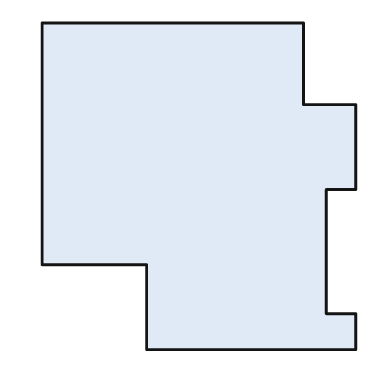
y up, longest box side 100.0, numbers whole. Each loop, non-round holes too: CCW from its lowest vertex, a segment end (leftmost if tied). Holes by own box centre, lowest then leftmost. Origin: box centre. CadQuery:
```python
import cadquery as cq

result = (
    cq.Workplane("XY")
    .moveTo(-16.0, -50.0)
    .lineTo(48.0, -50.0)
    .lineTo(48.0, -39.0)
    .lineTo(39.0, -39.0)
    .lineTo(39.0, -1.0)
    .lineTo(48.0, -1.0)
    .lineTo(48.0, 25.0)
    .lineTo(32.0, 25.0)
    .lineTo(32.0, 50.0)
    .lineTo(-48.0, 50.0)
    .lineTo(-48.0, -24.0)
    .lineTo(-16.0, -24.0)
    .close()
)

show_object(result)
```